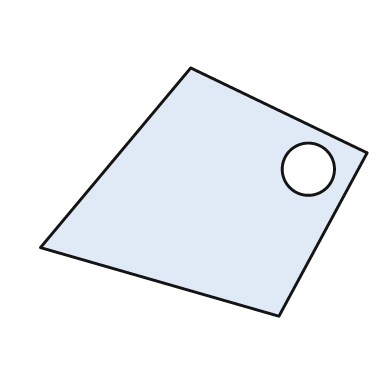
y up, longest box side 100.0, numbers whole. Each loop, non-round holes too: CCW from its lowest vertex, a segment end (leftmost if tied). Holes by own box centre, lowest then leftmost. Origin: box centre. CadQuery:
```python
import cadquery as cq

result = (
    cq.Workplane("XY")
    .moveTo(23.0, -38.0)
    .lineTo(50.0, 12.0)
    .lineTo(-4.0, 38.0)
    .lineTo(-50.0, -17.0)
    .close()
    .moveTo(32.0, 7.0)
    .circle(8.0)
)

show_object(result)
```